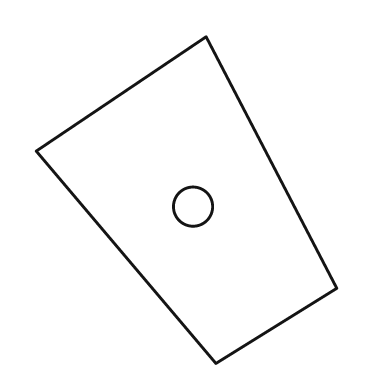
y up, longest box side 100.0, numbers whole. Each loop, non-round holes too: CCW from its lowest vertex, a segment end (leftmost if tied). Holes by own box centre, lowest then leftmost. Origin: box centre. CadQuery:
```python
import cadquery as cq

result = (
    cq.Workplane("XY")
    .moveTo(9.0, -50.0)
    .lineTo(46.0, -27.0)
    .lineTo(6.0, 50.0)
    .lineTo(-46.0, 15.0)
    .close()
    .moveTo(2.0, -2.0)
    .circle(6.0)
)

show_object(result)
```